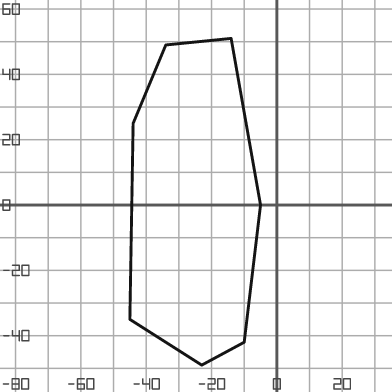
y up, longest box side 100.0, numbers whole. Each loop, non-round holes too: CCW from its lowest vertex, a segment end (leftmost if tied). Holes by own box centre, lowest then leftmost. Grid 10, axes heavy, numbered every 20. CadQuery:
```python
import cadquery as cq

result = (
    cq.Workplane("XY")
    .moveTo(-23.0, -49.0)
    .lineTo(-10.0, -42.0)
    .lineTo(-5.0, 0.0)
    .lineTo(-14.0, 51.0)
    .lineTo(-34.0, 49.0)
    .lineTo(-44.0, 25.0)
    .lineTo(-45.0, -35.0)
    .close()
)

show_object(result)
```